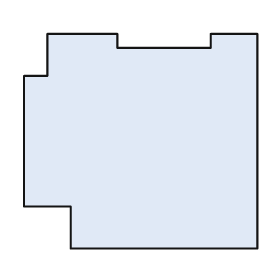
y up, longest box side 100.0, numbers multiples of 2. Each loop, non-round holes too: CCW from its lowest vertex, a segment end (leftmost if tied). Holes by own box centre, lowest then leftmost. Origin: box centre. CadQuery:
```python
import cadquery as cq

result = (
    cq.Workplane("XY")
    .moveTo(-30.0, -46.0)
    .lineTo(50.0, -46.0)
    .lineTo(50.0, 46.0)
    .lineTo(30.0, 46.0)
    .lineTo(30.0, 40.0)
    .lineTo(-10.0, 40.0)
    .lineTo(-10.0, 46.0)
    .lineTo(-40.0, 46.0)
    .lineTo(-40.0, 28.0)
    .lineTo(-50.0, 28.0)
    .lineTo(-50.0, -28.0)
    .lineTo(-30.0, -28.0)
    .close()
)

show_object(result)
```